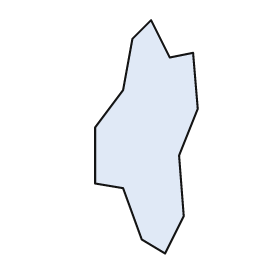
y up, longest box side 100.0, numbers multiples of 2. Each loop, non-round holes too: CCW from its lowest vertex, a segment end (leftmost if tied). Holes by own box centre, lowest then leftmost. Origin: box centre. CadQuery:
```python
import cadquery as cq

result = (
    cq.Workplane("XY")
    .moveTo(8.0, -50.0)
    .lineTo(16.0, -34.0)
    .lineTo(14.0, -8.0)
    .lineTo(22.0, 12.0)
    .lineTo(20.0, 36.0)
    .lineTo(10.0, 34.0)
    .lineTo(2.0, 50.0)
    .lineTo(-6.0, 42.0)
    .lineTo(-10.0, 20.0)
    .lineTo(-22.0, 4.0)
    .lineTo(-22.0, -20.0)
    .lineTo(-10.0, -22.0)
    .lineTo(-2.0, -44.0)
    .close()
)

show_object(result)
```